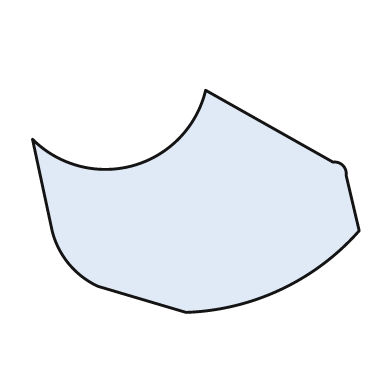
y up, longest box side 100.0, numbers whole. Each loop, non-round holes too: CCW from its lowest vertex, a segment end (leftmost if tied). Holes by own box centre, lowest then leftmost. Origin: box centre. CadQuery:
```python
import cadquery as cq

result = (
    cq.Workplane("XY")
    .moveTo(-3.0, -34.0)
    .threePointArc((26.0, -27.0), (50.0, -9.0))
    .lineTo(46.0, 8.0)
    .threePointArc((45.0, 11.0), (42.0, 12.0))
    .lineTo(3.0, 34.0)
    .threePointArc((-19.0, 11.0), (-50.0, 19.0))
    .lineTo(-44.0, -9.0)
    .threePointArc((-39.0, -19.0), (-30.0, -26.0))
    .close()
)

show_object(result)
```